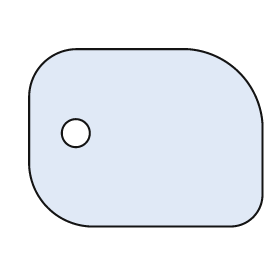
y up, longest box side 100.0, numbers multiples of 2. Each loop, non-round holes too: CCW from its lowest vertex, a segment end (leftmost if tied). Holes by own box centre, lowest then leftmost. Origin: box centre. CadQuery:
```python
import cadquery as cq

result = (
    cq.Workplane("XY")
    .moveTo(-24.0, -38.0)
    .lineTo(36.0, -38.0)
    .threePointArc((46.0, -34.0), (50.0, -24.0))
    .lineTo(50.0, 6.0)
    .threePointArc((40.0, 28.0), (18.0, 38.0))
    .lineTo(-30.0, 38.0)
    .threePointArc((-44.0, 32.0), (-50.0, 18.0))
    .lineTo(-50.0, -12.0)
    .threePointArc((-42.0, -30.0), (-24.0, -38.0))
    .close()
    .moveTo(-30.0, 2.0)
    .circle(6.0)
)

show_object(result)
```